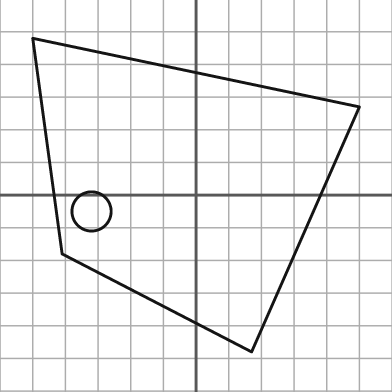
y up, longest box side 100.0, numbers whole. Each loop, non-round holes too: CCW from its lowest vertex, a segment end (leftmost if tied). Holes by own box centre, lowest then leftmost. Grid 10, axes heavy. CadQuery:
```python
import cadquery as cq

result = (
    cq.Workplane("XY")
    .moveTo(17.0, -48.0)
    .lineTo(50.0, 27.0)
    .lineTo(-50.0, 48.0)
    .lineTo(-41.0, -18.0)
    .close()
    .moveTo(-32.0, -5.0)
    .circle(6.0)
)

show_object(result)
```